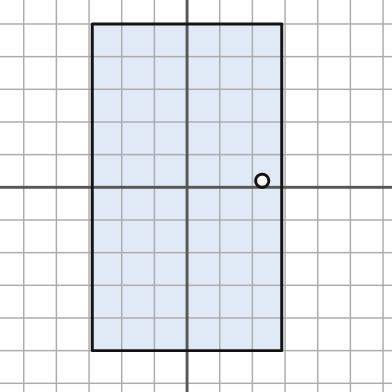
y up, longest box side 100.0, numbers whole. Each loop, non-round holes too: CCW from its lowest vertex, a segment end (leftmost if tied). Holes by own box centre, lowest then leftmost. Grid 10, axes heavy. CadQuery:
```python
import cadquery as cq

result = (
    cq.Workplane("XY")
    .moveTo(-29.0, -50.0)
    .lineTo(29.0, -50.0)
    .lineTo(29.0, 50.0)
    .lineTo(-29.0, 50.0)
    .close()
    .moveTo(23.0, 2.0)
    .circle(2.0)
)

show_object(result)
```